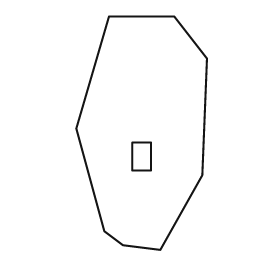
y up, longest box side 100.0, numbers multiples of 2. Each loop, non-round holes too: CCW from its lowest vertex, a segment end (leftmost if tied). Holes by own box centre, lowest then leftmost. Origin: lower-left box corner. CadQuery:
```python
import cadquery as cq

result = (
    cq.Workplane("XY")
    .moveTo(36.0, 0.0)
    .lineTo(54.0, 32.0)
    .lineTo(56.0, 82.0)
    .lineTo(42.0, 100.0)
    .lineTo(14.0, 100.0)
    .lineTo(0.0, 52.0)
    .lineTo(12.0, 8.0)
    .lineTo(20.0, 2.0)
    .close()
    .moveTo(24.0, 34.0)
    .lineTo(32.0, 34.0)
    .lineTo(32.0, 46.0)
    .lineTo(24.0, 46.0)
    .close()
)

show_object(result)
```